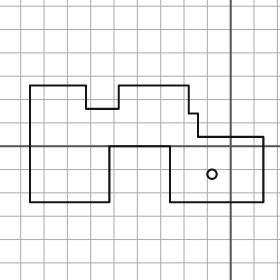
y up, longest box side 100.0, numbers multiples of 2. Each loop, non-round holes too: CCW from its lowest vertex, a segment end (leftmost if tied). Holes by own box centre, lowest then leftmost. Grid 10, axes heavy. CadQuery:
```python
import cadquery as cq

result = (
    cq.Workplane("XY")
    .moveTo(-86.0, -24.0)
    .lineTo(-52.0, -24.0)
    .lineTo(-52.0, 0.0)
    .lineTo(-26.0, 0.0)
    .lineTo(-26.0, -24.0)
    .lineTo(14.0, -24.0)
    .lineTo(14.0, 4.0)
    .lineTo(-14.0, 4.0)
    .lineTo(-14.0, 14.0)
    .lineTo(-18.0, 14.0)
    .lineTo(-18.0, 26.0)
    .lineTo(-48.0, 26.0)
    .lineTo(-48.0, 16.0)
    .lineTo(-62.0, 16.0)
    .lineTo(-62.0, 26.0)
    .lineTo(-86.0, 26.0)
    .close()
    .moveTo(-8.0, -12.0)
    .circle(2.0)
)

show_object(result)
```